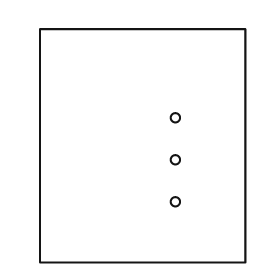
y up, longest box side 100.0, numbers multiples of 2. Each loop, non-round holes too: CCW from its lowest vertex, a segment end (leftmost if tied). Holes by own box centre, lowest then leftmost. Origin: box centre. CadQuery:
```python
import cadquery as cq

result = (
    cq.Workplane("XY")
    .moveTo(-44.0, -50.0)
    .lineTo(44.0, -50.0)
    .lineTo(44.0, 50.0)
    .lineTo(-44.0, 50.0)
    .close()
    .moveTo(14.0, -24.0)
    .circle(2.0)
    .moveTo(14.0, -6.0)
    .circle(2.0)
    .moveTo(14.0, 12.0)
    .circle(2.0)
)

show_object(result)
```